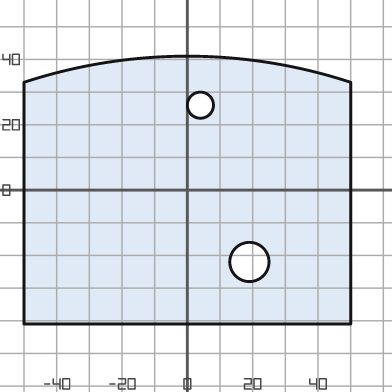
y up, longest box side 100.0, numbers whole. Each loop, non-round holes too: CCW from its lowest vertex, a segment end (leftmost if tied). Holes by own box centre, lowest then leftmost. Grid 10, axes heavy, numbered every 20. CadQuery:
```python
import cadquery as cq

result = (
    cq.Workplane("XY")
    .moveTo(-50.0, -41.0)
    .lineTo(50.0, -41.0)
    .lineTo(50.0, 33.0)
    .threePointArc((0.0, 41.0), (-50.0, 33.0))
    .close()
    .moveTo(19.0, -22.0)
    .circle(6.0)
    .moveTo(4.0, 26.0)
    .circle(4.0)
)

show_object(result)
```